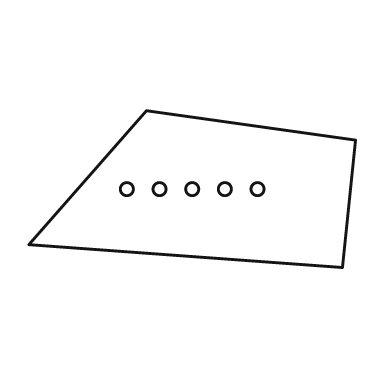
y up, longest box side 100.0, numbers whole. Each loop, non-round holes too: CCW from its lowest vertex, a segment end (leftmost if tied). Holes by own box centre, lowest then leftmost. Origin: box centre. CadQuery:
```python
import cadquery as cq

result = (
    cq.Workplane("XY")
    .moveTo(46.0, -24.0)
    .lineTo(50.0, 15.0)
    .lineTo(-14.0, 24.0)
    .lineTo(-50.0, -17.0)
    .close()
    .moveTo(-20.0, 0.0)
    .circle(2.0)
    .moveTo(-10.0, 0.0)
    .circle(2.0)
    .moveTo(0.0, 0.0)
    .circle(2.0)
    .moveTo(10.0, 0.0)
    .circle(2.0)
    .moveTo(20.0, 0.0)
    .circle(2.0)
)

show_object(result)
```